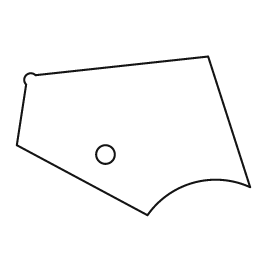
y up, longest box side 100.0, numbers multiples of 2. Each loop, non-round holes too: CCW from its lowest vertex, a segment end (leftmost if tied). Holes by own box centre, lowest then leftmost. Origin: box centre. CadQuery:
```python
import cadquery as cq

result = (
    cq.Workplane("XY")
    .moveTo(6.0, -34.0)
    .threePointArc((26.0, -20.0), (50.0, -22.0))
    .lineTo(32.0, 34.0)
    .lineTo(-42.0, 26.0)
    .threePointArc((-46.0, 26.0), (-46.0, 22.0))
    .lineTo(-50.0, -4.0)
    .close()
    .moveTo(-12.0, -8.0)
    .circle(4.0)
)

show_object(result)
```